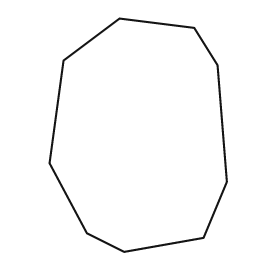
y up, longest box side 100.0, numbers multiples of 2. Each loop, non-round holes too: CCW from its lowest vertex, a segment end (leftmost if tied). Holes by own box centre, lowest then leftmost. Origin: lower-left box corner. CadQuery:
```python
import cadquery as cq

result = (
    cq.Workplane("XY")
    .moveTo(32.0, 0.0)
    .lineTo(66.0, 6.0)
    .lineTo(76.0, 30.0)
    .lineTo(72.0, 80.0)
    .lineTo(62.0, 96.0)
    .lineTo(30.0, 100.0)
    .lineTo(6.0, 82.0)
    .lineTo(0.0, 38.0)
    .lineTo(16.0, 8.0)
    .close()
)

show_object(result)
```